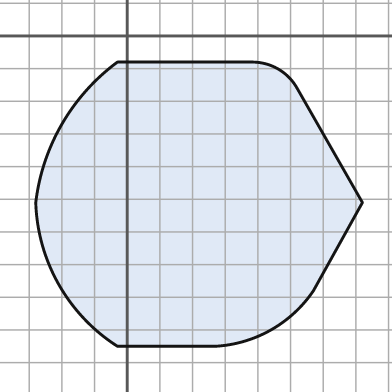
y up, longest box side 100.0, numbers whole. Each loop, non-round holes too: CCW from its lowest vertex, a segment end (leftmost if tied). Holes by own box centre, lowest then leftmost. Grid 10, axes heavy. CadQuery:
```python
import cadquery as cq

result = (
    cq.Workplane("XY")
    .moveTo(-3.0, -95.0)
    .lineTo(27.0, -95.0)
    .threePointArc((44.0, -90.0), (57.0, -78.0))
    .lineTo(72.0, -51.0)
    .lineTo(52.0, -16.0)
    .threePointArc((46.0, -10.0), (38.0, -8.0))
    .lineTo(-3.0, -8.0)
    .threePointArc((-20.0, -27.0), (-28.0, -51.0))
    .threePointArc((-21.0, -76.0), (-3.0, -95.0))
    .close()
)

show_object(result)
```